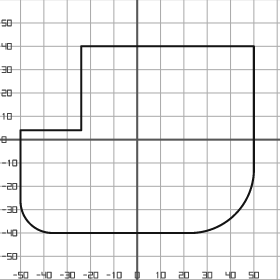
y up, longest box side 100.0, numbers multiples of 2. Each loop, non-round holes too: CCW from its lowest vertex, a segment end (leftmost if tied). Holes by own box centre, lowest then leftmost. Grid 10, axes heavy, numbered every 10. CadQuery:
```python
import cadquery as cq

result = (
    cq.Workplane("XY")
    .moveTo(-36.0, -40.0)
    .lineTo(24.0, -40.0)
    .threePointArc((42.0, -32.0), (50.0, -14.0))
    .lineTo(50.0, 40.0)
    .lineTo(-24.0, 40.0)
    .lineTo(-24.0, 4.0)
    .lineTo(-50.0, 4.0)
    .lineTo(-50.0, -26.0)
    .threePointArc((-46.0, -36.0), (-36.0, -40.0))
    .close()
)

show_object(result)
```